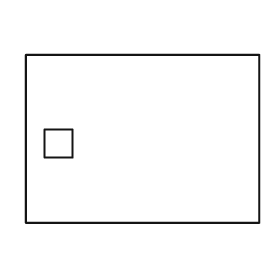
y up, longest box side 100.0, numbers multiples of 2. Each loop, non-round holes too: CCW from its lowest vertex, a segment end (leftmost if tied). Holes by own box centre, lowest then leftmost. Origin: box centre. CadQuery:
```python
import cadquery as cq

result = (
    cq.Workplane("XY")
    .moveTo(-50.0, -36.0)
    .lineTo(50.0, -36.0)
    .lineTo(50.0, 36.0)
    .lineTo(-50.0, 36.0)
    .close()
    .moveTo(-42.0, -8.0)
    .lineTo(-30.0, -8.0)
    .lineTo(-30.0, 4.0)
    .lineTo(-42.0, 4.0)
    .close()
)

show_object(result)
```